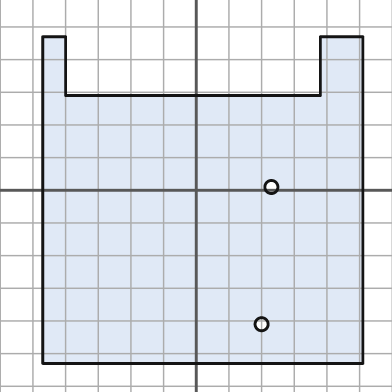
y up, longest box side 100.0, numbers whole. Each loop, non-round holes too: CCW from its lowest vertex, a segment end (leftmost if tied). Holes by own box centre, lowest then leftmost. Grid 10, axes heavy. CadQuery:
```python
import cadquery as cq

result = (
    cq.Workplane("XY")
    .moveTo(-47.0, -53.0)
    .lineTo(51.0, -53.0)
    .lineTo(51.0, 47.0)
    .lineTo(38.0, 47.0)
    .lineTo(38.0, 29.0)
    .lineTo(-40.0, 29.0)
    .lineTo(-40.0, 47.0)
    .lineTo(-47.0, 47.0)
    .close()
    .moveTo(20.0, -41.0)
    .circle(2.0)
    .moveTo(23.0, 1.0)
    .circle(2.0)
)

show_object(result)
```